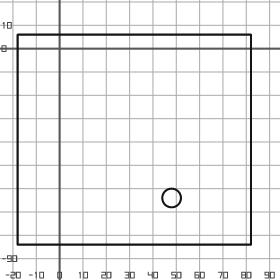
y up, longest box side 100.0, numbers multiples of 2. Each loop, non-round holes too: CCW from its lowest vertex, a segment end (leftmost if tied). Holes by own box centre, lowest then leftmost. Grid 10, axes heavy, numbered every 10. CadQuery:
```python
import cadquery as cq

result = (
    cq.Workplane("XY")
    .moveTo(-18.0, -84.0)
    .lineTo(82.0, -84.0)
    .lineTo(82.0, 6.0)
    .lineTo(-18.0, 6.0)
    .close()
    .moveTo(48.0, -64.0)
    .circle(4.0)
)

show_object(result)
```